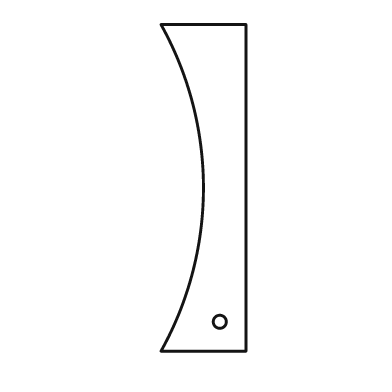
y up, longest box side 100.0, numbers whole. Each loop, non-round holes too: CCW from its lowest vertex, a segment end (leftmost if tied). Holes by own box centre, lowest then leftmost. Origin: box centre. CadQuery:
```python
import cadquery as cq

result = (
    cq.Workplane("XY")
    .moveTo(-13.0, -50.0)
    .lineTo(13.0, -50.0)
    .lineTo(13.0, 50.0)
    .lineTo(-13.0, 50.0)
    .threePointArc((0.0, 0.0), (-13.0, -50.0))
    .close()
    .moveTo(5.0, -41.0)
    .circle(2.0)
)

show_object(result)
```